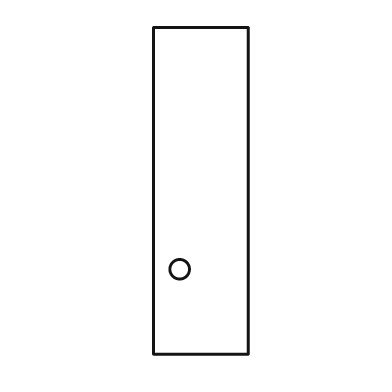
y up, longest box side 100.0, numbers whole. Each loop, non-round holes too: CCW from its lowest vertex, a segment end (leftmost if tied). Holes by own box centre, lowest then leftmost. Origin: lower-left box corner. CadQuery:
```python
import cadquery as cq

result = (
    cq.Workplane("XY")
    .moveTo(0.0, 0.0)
    .lineTo(29.0, 0.0)
    .lineTo(29.0, 100.0)
    .lineTo(0.0, 100.0)
    .close()
    .moveTo(8.0, 26.0)
    .circle(3.0)
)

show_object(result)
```